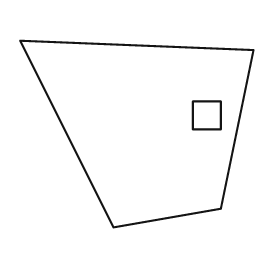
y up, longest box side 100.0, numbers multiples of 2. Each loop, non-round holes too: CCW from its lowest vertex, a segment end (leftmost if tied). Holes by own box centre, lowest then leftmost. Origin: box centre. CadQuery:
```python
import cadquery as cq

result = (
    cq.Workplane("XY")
    .moveTo(-10.0, -40.0)
    .lineTo(36.0, -32.0)
    .lineTo(50.0, 36.0)
    .lineTo(-50.0, 40.0)
    .close()
    .moveTo(24.0, 2.0)
    .lineTo(36.0, 2.0)
    .lineTo(36.0, 14.0)
    .lineTo(24.0, 14.0)
    .close()
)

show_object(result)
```